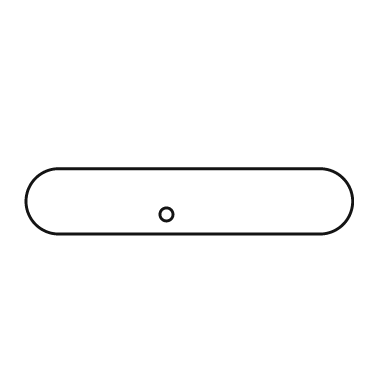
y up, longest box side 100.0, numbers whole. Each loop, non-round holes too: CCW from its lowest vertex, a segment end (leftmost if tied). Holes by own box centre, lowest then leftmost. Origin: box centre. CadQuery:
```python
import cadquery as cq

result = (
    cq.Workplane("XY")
    .moveTo(-40.0, -10.0)
    .lineTo(40.0, -10.0)
    .threePointArc((50.0, 0.0), (40.0, 10.0))
    .lineTo(-40.0, 10.0)
    .threePointArc((-50.0, 0.0), (-40.0, -10.0))
    .close()
    .moveTo(-7.0, -4.0)
    .circle(2.0)
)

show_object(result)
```